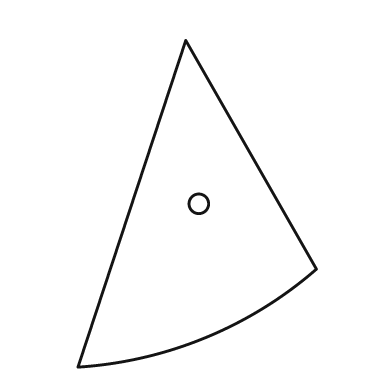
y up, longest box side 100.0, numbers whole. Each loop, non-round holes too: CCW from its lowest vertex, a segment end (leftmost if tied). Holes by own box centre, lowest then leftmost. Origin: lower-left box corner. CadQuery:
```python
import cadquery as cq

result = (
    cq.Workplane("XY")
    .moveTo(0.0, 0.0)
    .threePointArc((39.0, 9.0), (73.0, 30.0))
    .lineTo(33.0, 100.0)
    .close()
    .moveTo(37.0, 50.0)
    .circle(3.0)
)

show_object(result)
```